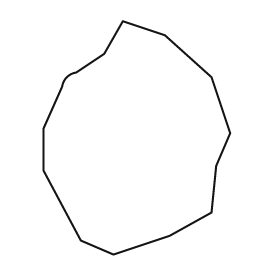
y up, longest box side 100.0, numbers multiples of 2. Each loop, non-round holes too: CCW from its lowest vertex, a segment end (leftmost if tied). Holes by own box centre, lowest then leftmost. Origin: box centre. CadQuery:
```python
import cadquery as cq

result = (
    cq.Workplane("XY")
    .moveTo(-10.0, -50.0)
    .lineTo(14.0, -42.0)
    .lineTo(32.0, -32.0)
    .lineTo(34.0, -12.0)
    .lineTo(40.0, 2.0)
    .lineTo(32.0, 26.0)
    .lineTo(12.0, 44.0)
    .lineTo(-6.0, 50.0)
    .lineTo(-14.0, 36.0)
    .lineTo(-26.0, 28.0)
    .threePointArc((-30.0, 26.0), (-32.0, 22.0))
    .lineTo(-40.0, 4.0)
    .lineTo(-40.0, -14.0)
    .lineTo(-24.0, -44.0)
    .close()
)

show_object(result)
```